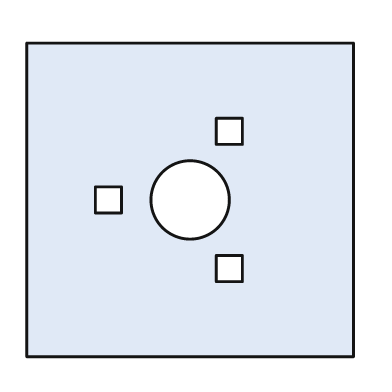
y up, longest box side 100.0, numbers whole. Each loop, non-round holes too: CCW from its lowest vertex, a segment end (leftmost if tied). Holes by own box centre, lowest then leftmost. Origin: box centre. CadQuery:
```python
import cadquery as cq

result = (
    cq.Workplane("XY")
    .moveTo(-50.0, -48.0)
    .lineTo(50.0, -48.0)
    .lineTo(50.0, 48.0)
    .lineTo(-50.0, 48.0)
    .close()
    .moveTo(8.0, -25.0)
    .lineTo(16.0, -25.0)
    .lineTo(16.0, -17.0)
    .lineTo(8.0, -17.0)
    .close()
    .moveTo(-29.0, -4.0)
    .lineTo(-21.0, -4.0)
    .lineTo(-21.0, 4.0)
    .lineTo(-29.0, 4.0)
    .close()
    .moveTo(0.0, 0.0)
    .circle(12.0)
    .moveTo(8.0, 17.0)
    .lineTo(16.0, 17.0)
    .lineTo(16.0, 25.0)
    .lineTo(8.0, 25.0)
    .close()
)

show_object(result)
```